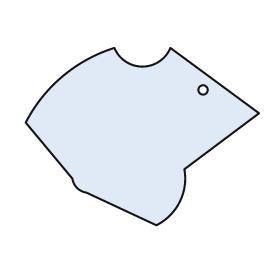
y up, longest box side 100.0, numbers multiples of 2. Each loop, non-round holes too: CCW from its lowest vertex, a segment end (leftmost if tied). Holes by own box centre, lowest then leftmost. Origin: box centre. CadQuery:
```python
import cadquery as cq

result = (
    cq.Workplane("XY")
    .moveTo(6.0, -38.0)
    .threePointArc((16.0, -28.0), (18.0, -14.0))
    .lineTo(50.0, 10.0)
    .lineTo(12.0, 38.0)
    .threePointArc((0.0, 30.0), (-12.0, 38.0))
    .threePointArc((-34.0, 26.0), (-50.0, 6.0))
    .lineTo(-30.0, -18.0)
    .threePointArc((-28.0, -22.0), (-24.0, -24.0))
    .close()
    .moveTo(26.0, 20.0)
    .circle(2.0)
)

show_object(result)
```